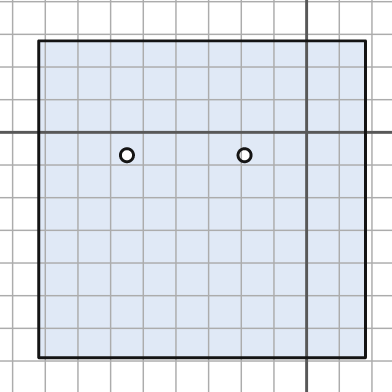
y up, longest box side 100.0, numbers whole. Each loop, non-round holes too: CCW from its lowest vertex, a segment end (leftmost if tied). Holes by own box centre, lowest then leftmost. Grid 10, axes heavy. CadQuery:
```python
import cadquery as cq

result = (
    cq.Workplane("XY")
    .moveTo(-82.0, -69.0)
    .lineTo(18.0, -69.0)
    .lineTo(18.0, 28.0)
    .lineTo(-82.0, 28.0)
    .close()
    .moveTo(-55.0, -7.0)
    .circle(2.0)
    .moveTo(-19.0, -7.0)
    .circle(2.0)
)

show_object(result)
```